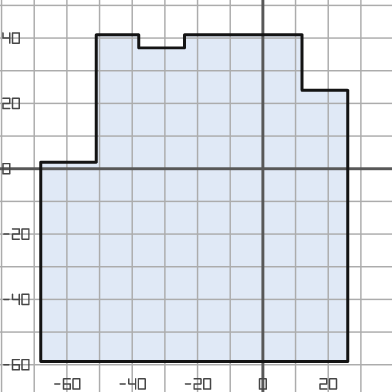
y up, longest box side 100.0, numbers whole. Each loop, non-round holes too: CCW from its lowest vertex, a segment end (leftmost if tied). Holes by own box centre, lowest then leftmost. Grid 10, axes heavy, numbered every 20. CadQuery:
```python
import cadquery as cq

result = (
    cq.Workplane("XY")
    .moveTo(-68.0, -59.0)
    .lineTo(26.0, -59.0)
    .lineTo(26.0, 24.0)
    .lineTo(12.0, 24.0)
    .lineTo(12.0, 41.0)
    .lineTo(-24.0, 41.0)
    .lineTo(-24.0, 37.0)
    .lineTo(-38.0, 37.0)
    .lineTo(-38.0, 41.0)
    .lineTo(-51.0, 41.0)
    .lineTo(-51.0, 2.0)
    .lineTo(-68.0, 2.0)
    .close()
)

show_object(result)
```